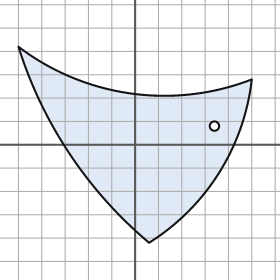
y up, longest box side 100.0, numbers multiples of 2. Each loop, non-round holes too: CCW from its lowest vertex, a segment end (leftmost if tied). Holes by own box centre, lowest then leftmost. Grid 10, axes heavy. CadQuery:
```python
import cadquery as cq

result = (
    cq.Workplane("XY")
    .moveTo(6.0, -42.0)
    .threePointArc((36.0, -12.0), (50.0, 28.0))
    .threePointArc((-2.0, 22.0), (-50.0, 42.0))
    .threePointArc((-28.0, -4.0), (6.0, -42.0))
    .close()
    .moveTo(34.0, 8.0)
    .circle(2.0)
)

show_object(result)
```